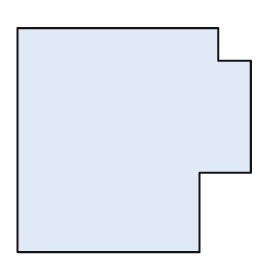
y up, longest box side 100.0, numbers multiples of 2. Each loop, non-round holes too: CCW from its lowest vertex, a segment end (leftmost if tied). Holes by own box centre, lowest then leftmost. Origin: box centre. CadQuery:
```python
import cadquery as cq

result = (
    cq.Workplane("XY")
    .moveTo(-50.0, -48.0)
    .lineTo(28.0, -48.0)
    .lineTo(28.0, -14.0)
    .lineTo(50.0, -14.0)
    .lineTo(50.0, 34.0)
    .lineTo(36.0, 34.0)
    .lineTo(36.0, 48.0)
    .lineTo(-50.0, 48.0)
    .close()
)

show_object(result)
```